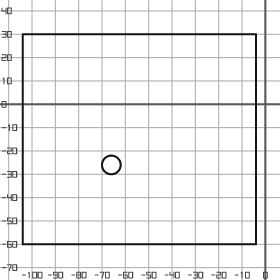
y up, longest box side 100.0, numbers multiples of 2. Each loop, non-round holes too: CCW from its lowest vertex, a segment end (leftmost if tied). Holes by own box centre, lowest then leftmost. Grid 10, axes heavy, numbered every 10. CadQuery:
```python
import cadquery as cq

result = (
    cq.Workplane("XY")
    .moveTo(-104.0, -60.0)
    .lineTo(-4.0, -60.0)
    .lineTo(-4.0, 30.0)
    .lineTo(-104.0, 30.0)
    .close()
    .moveTo(-66.0, -26.0)
    .circle(4.0)
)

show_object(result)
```